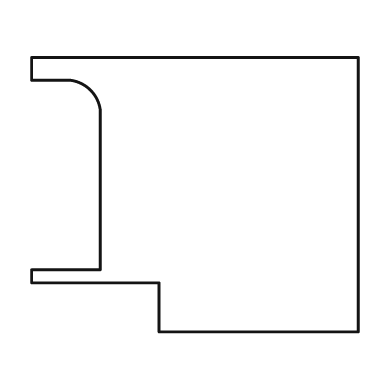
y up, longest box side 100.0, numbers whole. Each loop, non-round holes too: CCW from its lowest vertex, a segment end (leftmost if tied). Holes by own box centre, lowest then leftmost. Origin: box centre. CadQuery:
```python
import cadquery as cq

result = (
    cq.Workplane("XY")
    .moveTo(-11.0, -42.0)
    .lineTo(50.0, -42.0)
    .lineTo(50.0, 42.0)
    .lineTo(-50.0, 42.0)
    .lineTo(-50.0, 35.0)
    .lineTo(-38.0, 35.0)
    .threePointArc((-32.0, 32.0), (-29.0, 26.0))
    .lineTo(-29.0, -23.0)
    .lineTo(-50.0, -23.0)
    .lineTo(-50.0, -27.0)
    .lineTo(-11.0, -27.0)
    .close()
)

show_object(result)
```